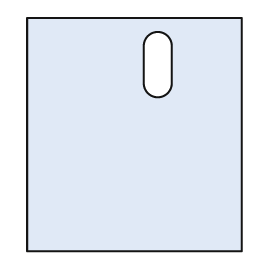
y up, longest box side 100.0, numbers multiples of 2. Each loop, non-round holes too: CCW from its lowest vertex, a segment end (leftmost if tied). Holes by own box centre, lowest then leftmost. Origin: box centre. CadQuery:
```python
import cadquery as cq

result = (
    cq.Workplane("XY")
    .moveTo(-46.0, -50.0)
    .lineTo(46.0, -50.0)
    .lineTo(46.0, 50.0)
    .lineTo(-46.0, 50.0)
    .close()
    .moveTo(4.0, 22.0)
    .threePointArc((10.0, 16.0), (16.0, 22.0))
    .lineTo(16.0, 38.0)
    .threePointArc((10.0, 44.0), (4.0, 38.0))
    .close()
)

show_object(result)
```